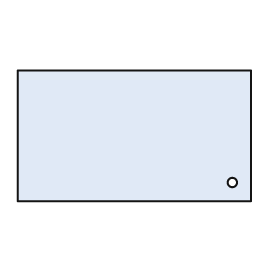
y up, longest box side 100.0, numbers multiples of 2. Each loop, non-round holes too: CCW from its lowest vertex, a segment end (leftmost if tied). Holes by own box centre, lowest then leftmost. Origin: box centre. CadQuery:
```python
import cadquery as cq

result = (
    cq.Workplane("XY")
    .moveTo(-50.0, -28.0)
    .lineTo(50.0, -28.0)
    .lineTo(50.0, 28.0)
    .lineTo(-50.0, 28.0)
    .close()
    .moveTo(42.0, -20.0)
    .circle(2.0)
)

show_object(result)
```